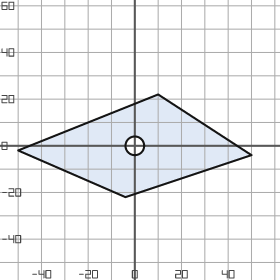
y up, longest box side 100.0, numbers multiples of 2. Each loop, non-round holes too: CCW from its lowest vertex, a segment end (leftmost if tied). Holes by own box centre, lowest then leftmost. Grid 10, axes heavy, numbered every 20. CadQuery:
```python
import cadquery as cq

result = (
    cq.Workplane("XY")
    .moveTo(-4.0, -22.0)
    .lineTo(50.0, -4.0)
    .lineTo(10.0, 22.0)
    .lineTo(-50.0, -2.0)
    .close()
    .moveTo(0.0, 0.0)
    .circle(4.0)
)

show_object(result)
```